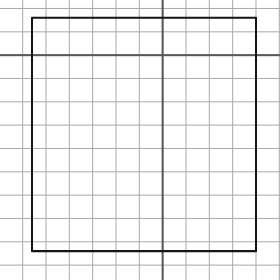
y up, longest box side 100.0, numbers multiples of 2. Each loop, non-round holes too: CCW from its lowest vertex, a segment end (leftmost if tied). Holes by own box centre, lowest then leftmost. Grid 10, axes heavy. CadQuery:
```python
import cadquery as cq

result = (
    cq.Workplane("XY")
    .moveTo(-56.0, -84.0)
    .lineTo(40.0, -84.0)
    .lineTo(40.0, 16.0)
    .lineTo(-56.0, 16.0)
    .close()
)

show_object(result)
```